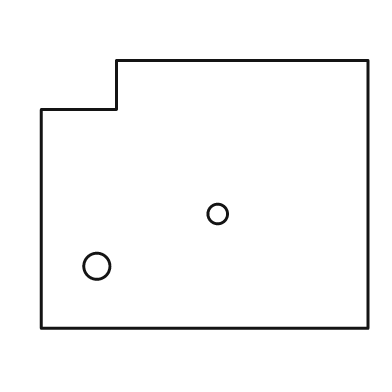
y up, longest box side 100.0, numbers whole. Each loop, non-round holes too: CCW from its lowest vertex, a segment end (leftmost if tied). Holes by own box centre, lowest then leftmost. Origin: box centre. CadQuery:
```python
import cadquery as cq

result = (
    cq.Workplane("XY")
    .moveTo(-50.0, -41.0)
    .lineTo(50.0, -41.0)
    .lineTo(50.0, 41.0)
    .lineTo(-27.0, 41.0)
    .lineTo(-27.0, 26.0)
    .lineTo(-50.0, 26.0)
    .close()
    .moveTo(-33.0, -22.0)
    .circle(4.0)
    .moveTo(4.0, -6.0)
    .circle(3.0)
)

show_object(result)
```